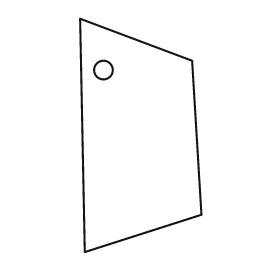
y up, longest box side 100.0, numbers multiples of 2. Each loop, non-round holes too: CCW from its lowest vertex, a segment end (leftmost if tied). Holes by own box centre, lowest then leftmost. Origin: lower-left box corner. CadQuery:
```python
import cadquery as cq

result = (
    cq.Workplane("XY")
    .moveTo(2.0, 0.0)
    .lineTo(52.0, 16.0)
    .lineTo(48.0, 82.0)
    .lineTo(0.0, 100.0)
    .close()
    .moveTo(10.0, 78.0)
    .circle(4.0)
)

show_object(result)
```